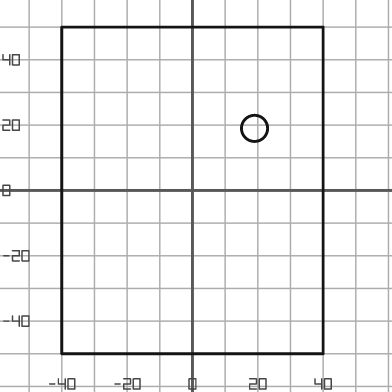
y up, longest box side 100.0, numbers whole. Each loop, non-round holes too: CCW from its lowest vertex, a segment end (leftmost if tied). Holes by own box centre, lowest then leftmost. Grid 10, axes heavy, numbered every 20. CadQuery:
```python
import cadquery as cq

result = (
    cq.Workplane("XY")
    .moveTo(-40.0, -50.0)
    .lineTo(40.0, -50.0)
    .lineTo(40.0, 50.0)
    .lineTo(-40.0, 50.0)
    .close()
    .moveTo(19.0, 19.0)
    .circle(4.0)
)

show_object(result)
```